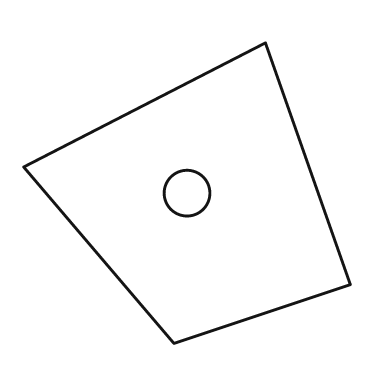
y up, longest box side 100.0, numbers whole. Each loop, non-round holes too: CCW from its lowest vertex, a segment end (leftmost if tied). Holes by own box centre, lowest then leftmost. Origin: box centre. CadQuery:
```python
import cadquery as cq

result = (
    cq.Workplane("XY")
    .moveTo(-4.0, -46.0)
    .lineTo(50.0, -28.0)
    .lineTo(24.0, 46.0)
    .lineTo(-50.0, 8.0)
    .close()
    .moveTo(0.0, 0.0)
    .circle(7.0)
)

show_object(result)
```